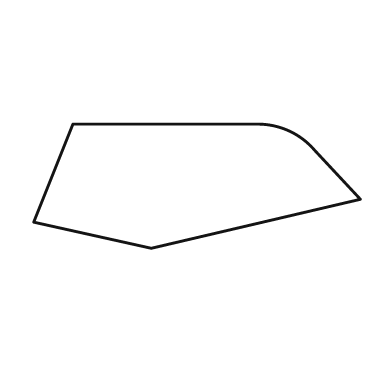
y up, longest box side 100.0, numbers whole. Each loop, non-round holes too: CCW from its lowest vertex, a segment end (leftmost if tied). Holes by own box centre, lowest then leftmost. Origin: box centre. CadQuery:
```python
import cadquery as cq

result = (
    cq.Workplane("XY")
    .moveTo(-14.0, -19.0)
    .lineTo(50.0, -4.0)
    .lineTo(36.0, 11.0)
    .threePointArc((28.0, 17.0), (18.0, 19.0))
    .lineTo(-38.0, 19.0)
    .lineTo(-50.0, -11.0)
    .close()
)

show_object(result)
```